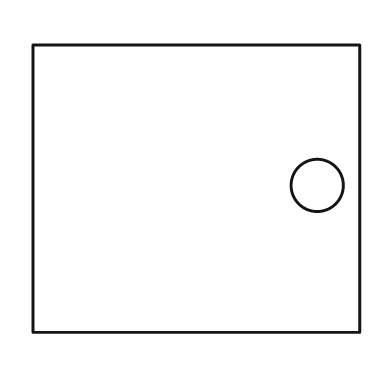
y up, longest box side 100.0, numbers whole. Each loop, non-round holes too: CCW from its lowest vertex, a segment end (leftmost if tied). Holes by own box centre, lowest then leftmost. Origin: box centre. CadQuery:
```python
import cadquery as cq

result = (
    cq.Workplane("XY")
    .moveTo(-50.0, -44.0)
    .lineTo(50.0, -44.0)
    .lineTo(50.0, 44.0)
    .lineTo(-50.0, 44.0)
    .close()
    .moveTo(37.0, 1.0)
    .circle(8.0)
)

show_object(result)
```